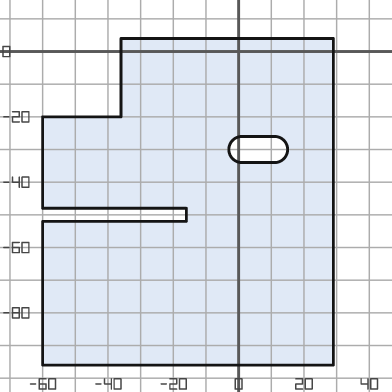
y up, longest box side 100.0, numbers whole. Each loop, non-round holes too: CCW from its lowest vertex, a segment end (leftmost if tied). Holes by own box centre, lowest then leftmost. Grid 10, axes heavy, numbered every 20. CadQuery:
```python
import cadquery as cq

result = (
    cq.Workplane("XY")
    .moveTo(-60.0, -96.0)
    .lineTo(29.0, -96.0)
    .lineTo(29.0, 4.0)
    .lineTo(-36.0, 4.0)
    .lineTo(-36.0, -20.0)
    .lineTo(-60.0, -20.0)
    .lineTo(-60.0, -48.0)
    .lineTo(-16.0, -48.0)
    .lineTo(-16.0, -52.0)
    .lineTo(-60.0, -52.0)
    .close()
    .moveTo(1.0, -34.0)
    .lineTo(11.0, -34.0)
    .threePointArc((15.0, -30.0), (11.0, -26.0))
    .lineTo(1.0, -26.0)
    .threePointArc((-3.0, -30.0), (1.0, -34.0))
    .close()
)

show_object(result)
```